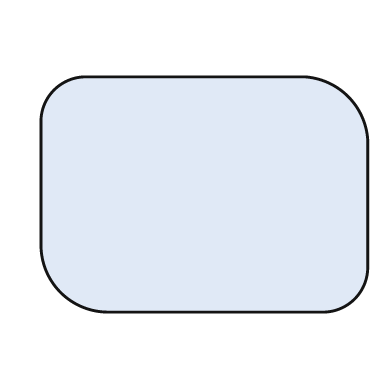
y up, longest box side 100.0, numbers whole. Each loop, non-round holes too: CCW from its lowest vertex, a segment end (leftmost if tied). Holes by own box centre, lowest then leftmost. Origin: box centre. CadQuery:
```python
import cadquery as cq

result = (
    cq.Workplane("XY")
    .moveTo(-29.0, -36.0)
    .lineTo(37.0, -36.0)
    .threePointArc((46.0, -32.0), (50.0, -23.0))
    .lineTo(50.0, 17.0)
    .threePointArc((44.0, 30.0), (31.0, 36.0))
    .lineTo(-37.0, 36.0)
    .threePointArc((-46.0, 32.0), (-50.0, 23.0))
    .lineTo(-50.0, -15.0)
    .threePointArc((-44.0, -30.0), (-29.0, -36.0))
    .close()
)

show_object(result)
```